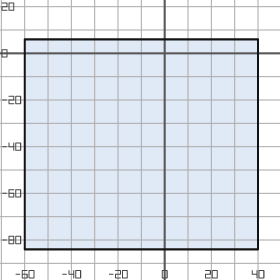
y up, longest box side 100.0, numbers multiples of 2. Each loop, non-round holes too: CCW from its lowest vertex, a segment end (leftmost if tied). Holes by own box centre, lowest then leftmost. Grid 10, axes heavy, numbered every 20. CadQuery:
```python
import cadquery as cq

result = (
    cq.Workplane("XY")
    .moveTo(-60.0, -84.0)
    .lineTo(40.0, -84.0)
    .lineTo(40.0, 6.0)
    .lineTo(-60.0, 6.0)
    .close()
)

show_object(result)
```